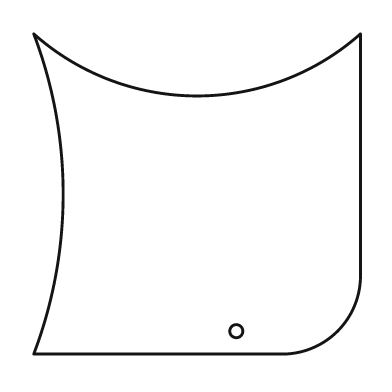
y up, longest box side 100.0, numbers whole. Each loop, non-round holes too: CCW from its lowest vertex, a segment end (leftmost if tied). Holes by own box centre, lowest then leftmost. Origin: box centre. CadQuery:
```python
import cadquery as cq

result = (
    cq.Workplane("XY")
    .moveTo(-50.0, -49.0)
    .lineTo(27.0, -49.0)
    .threePointArc((43.0, -42.0), (50.0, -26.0))
    .lineTo(50.0, 49.0)
    .threePointArc((0.0, 30.0), (-50.0, 49.0))
    .threePointArc((-41.0, 0.0), (-50.0, -49.0))
    .close()
    .moveTo(12.0, -42.0)
    .circle(2.0)
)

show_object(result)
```